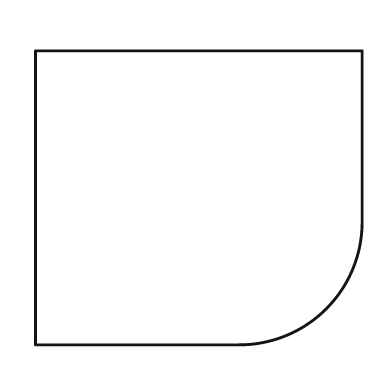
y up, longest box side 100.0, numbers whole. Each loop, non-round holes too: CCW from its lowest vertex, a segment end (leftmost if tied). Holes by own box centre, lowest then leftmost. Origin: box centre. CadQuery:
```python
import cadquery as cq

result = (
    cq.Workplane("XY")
    .moveTo(-50.0, -45.0)
    .lineTo(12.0, -45.0)
    .threePointArc((39.0, -34.0), (50.0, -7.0))
    .lineTo(50.0, 45.0)
    .lineTo(-50.0, 45.0)
    .close()
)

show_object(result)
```